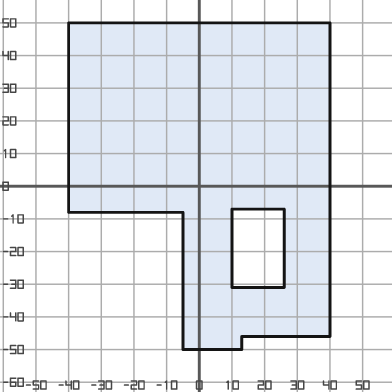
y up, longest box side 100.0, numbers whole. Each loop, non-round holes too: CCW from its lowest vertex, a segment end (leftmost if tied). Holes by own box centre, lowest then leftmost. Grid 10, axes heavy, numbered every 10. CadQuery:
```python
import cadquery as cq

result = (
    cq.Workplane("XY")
    .moveTo(-5.0, -50.0)
    .lineTo(13.0, -50.0)
    .lineTo(13.0, -46.0)
    .lineTo(40.0, -46.0)
    .lineTo(40.0, 50.0)
    .lineTo(-40.0, 50.0)
    .lineTo(-40.0, -8.0)
    .lineTo(-5.0, -8.0)
    .close()
    .moveTo(10.0, -31.0)
    .lineTo(26.0, -31.0)
    .lineTo(26.0, -7.0)
    .lineTo(10.0, -7.0)
    .close()
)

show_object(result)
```